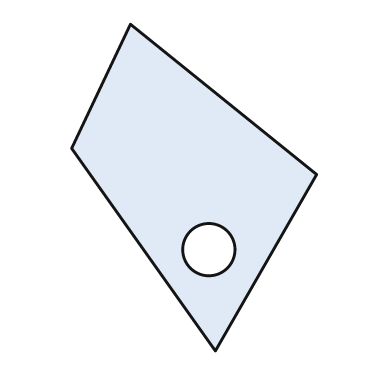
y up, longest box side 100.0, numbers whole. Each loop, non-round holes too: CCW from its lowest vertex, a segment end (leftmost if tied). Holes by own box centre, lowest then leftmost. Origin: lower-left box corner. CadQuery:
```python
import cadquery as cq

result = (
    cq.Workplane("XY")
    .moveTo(44.0, 0.0)
    .lineTo(75.0, 54.0)
    .lineTo(18.0, 100.0)
    .lineTo(0.0, 62.0)
    .close()
    .moveTo(42.0, 31.0)
    .circle(8.0)
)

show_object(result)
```